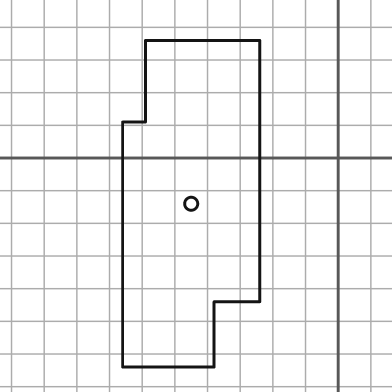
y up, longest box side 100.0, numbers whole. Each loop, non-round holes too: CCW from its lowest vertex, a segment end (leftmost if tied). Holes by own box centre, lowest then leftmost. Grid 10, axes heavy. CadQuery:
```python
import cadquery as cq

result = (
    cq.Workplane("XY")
    .moveTo(-66.0, -64.0)
    .lineTo(-38.0, -64.0)
    .lineTo(-38.0, -44.0)
    .lineTo(-24.0, -44.0)
    .lineTo(-24.0, 36.0)
    .lineTo(-59.0, 36.0)
    .lineTo(-59.0, 11.0)
    .lineTo(-66.0, 11.0)
    .close()
    .moveTo(-45.0, -14.0)
    .circle(2.0)
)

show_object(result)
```